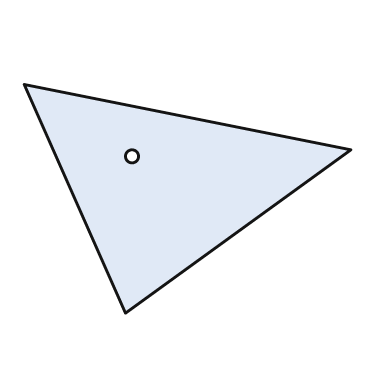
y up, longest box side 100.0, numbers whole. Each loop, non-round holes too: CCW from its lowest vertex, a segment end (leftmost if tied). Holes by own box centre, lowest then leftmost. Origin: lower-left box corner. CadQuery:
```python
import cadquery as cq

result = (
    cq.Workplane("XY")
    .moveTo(31.0, 0.0)
    .lineTo(100.0, 50.0)
    .lineTo(0.0, 70.0)
    .close()
    .moveTo(33.0, 48.0)
    .circle(2.0)
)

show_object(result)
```